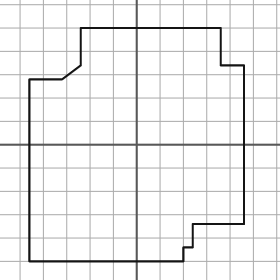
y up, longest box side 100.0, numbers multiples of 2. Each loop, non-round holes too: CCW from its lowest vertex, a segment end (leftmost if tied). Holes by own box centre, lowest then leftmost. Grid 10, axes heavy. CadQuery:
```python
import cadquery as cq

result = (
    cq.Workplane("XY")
    .moveTo(-46.0, -50.0)
    .lineTo(20.0, -50.0)
    .lineTo(20.0, -44.0)
    .lineTo(24.0, -44.0)
    .lineTo(24.0, -34.0)
    .lineTo(46.0, -34.0)
    .lineTo(46.0, 34.0)
    .lineTo(36.0, 34.0)
    .lineTo(36.0, 50.0)
    .lineTo(-24.0, 50.0)
    .lineTo(-24.0, 34.0)
    .lineTo(-32.0, 28.0)
    .lineTo(-46.0, 28.0)
    .close()
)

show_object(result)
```